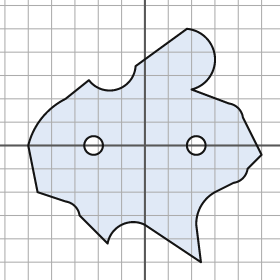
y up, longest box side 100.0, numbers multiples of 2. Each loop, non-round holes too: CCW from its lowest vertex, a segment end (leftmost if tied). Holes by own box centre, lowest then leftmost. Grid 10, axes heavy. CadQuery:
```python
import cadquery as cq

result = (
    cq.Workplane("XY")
    .moveTo(24.0, -50.0)
    .lineTo(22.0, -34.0)
    .threePointArc((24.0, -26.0), (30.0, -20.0))
    .lineTo(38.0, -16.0)
    .threePointArc((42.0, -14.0), (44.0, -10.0))
    .lineTo(50.0, -4.0)
    .lineTo(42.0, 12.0)
    .threePointArc((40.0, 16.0), (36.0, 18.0))
    .lineTo(20.0, 24.0)
    .threePointArc((30.0, 38.0), (18.0, 50.0))
    .lineTo(-4.0, 34.0)
    .threePointArc((-12.0, 24.0), (-24.0, 28.0))
    .lineTo(-34.0, 20.0)
    .threePointArc((-44.0, 12.0), (-50.0, 0.0))
    .lineTo(-46.0, -20.0)
    .lineTo(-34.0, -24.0)
    .threePointArc((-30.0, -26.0), (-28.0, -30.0))
    .lineTo(-16.0, -42.0)
    .threePointArc((-10.0, -34.0), (0.0, -34.0))
    .close()
    .moveTo(-22.0, 0.0)
    .circle(4.0)
    .moveTo(22.0, 0.0)
    .circle(4.0)
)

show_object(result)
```